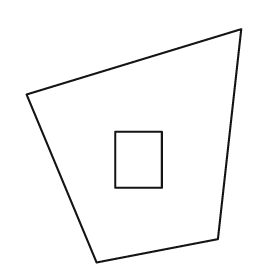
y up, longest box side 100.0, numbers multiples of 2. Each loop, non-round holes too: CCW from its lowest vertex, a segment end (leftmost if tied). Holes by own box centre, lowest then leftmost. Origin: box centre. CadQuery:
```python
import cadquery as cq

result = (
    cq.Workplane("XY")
    .moveTo(-16.0, -50.0)
    .lineTo(36.0, -40.0)
    .lineTo(46.0, 50.0)
    .lineTo(-46.0, 22.0)
    .close()
    .moveTo(-8.0, -18.0)
    .lineTo(12.0, -18.0)
    .lineTo(12.0, 6.0)
    .lineTo(-8.0, 6.0)
    .close()
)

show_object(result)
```